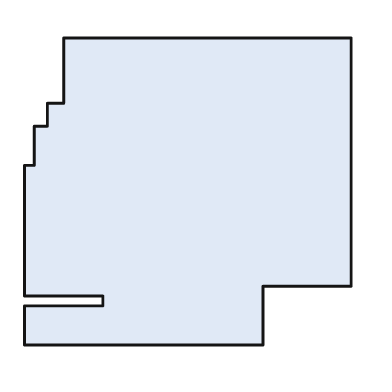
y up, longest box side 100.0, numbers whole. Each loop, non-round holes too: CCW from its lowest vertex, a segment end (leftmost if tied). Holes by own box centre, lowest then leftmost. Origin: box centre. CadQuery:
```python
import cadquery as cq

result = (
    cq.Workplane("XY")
    .moveTo(-50.0, -47.0)
    .lineTo(23.0, -47.0)
    .lineTo(23.0, -29.0)
    .lineTo(50.0, -29.0)
    .lineTo(50.0, 47.0)
    .lineTo(-38.0, 47.0)
    .lineTo(-38.0, 27.0)
    .lineTo(-43.0, 27.0)
    .lineTo(-43.0, 20.0)
    .lineTo(-47.0, 20.0)
    .lineTo(-47.0, 8.0)
    .lineTo(-50.0, 8.0)
    .lineTo(-50.0, -32.0)
    .lineTo(-26.0, -32.0)
    .lineTo(-26.0, -35.0)
    .lineTo(-50.0, -35.0)
    .close()
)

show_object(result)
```